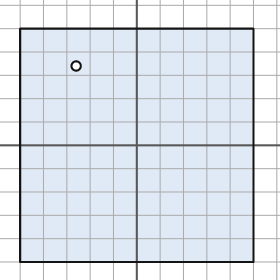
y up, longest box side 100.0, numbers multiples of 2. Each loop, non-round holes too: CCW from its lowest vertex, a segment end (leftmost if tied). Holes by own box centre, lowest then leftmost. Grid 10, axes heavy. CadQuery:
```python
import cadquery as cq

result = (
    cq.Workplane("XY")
    .moveTo(-50.0, -50.0)
    .lineTo(50.0, -50.0)
    .lineTo(50.0, 50.0)
    .lineTo(-50.0, 50.0)
    .close()
    .moveTo(-26.0, 34.0)
    .circle(2.0)
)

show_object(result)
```